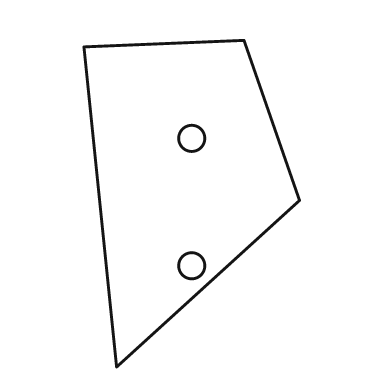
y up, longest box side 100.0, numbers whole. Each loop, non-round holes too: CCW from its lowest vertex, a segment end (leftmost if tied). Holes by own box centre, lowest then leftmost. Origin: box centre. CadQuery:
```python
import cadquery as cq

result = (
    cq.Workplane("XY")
    .moveTo(-23.0, -50.0)
    .lineTo(33.0, 1.0)
    .lineTo(16.0, 50.0)
    .lineTo(-33.0, 48.0)
    .close()
    .moveTo(0.0, -19.0)
    .circle(4.0)
    .moveTo(0.0, 20.0)
    .circle(4.0)
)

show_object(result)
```